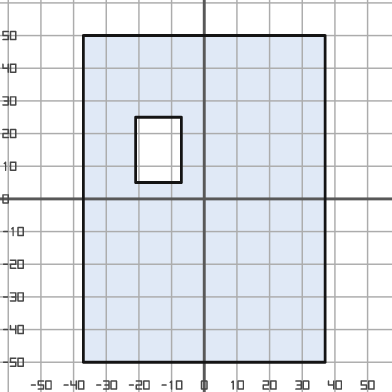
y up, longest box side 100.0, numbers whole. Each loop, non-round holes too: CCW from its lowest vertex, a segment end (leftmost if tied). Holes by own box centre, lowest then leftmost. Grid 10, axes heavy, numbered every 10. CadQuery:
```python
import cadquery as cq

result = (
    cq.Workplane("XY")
    .moveTo(-37.0, -50.0)
    .lineTo(37.0, -50.0)
    .lineTo(37.0, 50.0)
    .lineTo(-37.0, 50.0)
    .close()
    .moveTo(-21.0, 5.0)
    .lineTo(-7.0, 5.0)
    .lineTo(-7.0, 25.0)
    .lineTo(-21.0, 25.0)
    .close()
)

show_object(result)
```